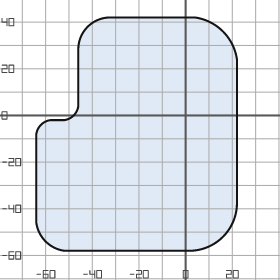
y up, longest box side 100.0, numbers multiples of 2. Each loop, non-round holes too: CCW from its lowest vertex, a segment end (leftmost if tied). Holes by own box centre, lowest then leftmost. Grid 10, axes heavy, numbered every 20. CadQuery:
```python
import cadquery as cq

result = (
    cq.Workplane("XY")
    .moveTo(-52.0, -58.0)
    .lineTo(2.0, -58.0)
    .threePointArc((16.0, -52.0), (22.0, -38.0))
    .lineTo(22.0, 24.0)
    .threePointArc((16.0, 36.0), (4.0, 42.0))
    .lineTo(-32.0, 42.0)
    .threePointArc((-42.0, 38.0), (-46.0, 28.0))
    .lineTo(-46.0, 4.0)
    .threePointArc((-48.0, 0.0), (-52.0, -2.0))
    .lineTo(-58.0, -2.0)
    .threePointArc((-62.0, -4.0), (-64.0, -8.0))
    .lineTo(-64.0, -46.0)
    .threePointArc((-60.0, -54.0), (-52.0, -58.0))
    .close()
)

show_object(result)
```